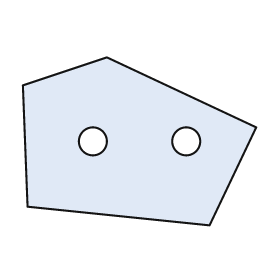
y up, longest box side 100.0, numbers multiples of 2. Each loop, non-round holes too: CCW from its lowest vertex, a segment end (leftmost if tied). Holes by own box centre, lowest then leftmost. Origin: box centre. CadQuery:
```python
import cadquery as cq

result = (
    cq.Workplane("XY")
    .moveTo(30.0, -36.0)
    .lineTo(50.0, 6.0)
    .lineTo(-14.0, 36.0)
    .lineTo(-50.0, 24.0)
    .lineTo(-48.0, -28.0)
    .close()
    .moveTo(-20.0, 0.0)
    .circle(6.0)
    .moveTo(20.0, 0.0)
    .circle(6.0)
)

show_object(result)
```